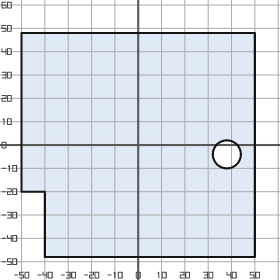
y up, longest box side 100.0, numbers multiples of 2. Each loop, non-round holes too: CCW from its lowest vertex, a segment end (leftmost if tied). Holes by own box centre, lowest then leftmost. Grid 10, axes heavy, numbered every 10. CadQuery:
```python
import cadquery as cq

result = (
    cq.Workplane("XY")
    .moveTo(-40.0, -48.0)
    .lineTo(50.0, -48.0)
    .lineTo(50.0, 48.0)
    .lineTo(-50.0, 48.0)
    .lineTo(-50.0, -20.0)
    .lineTo(-40.0, -20.0)
    .close()
    .moveTo(38.0, -4.0)
    .circle(6.0)
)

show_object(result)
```